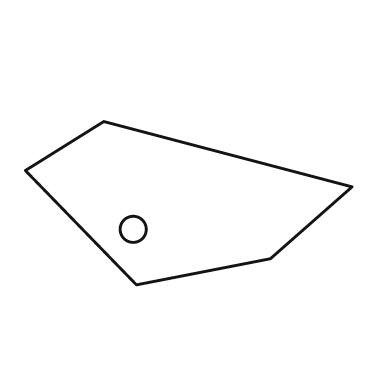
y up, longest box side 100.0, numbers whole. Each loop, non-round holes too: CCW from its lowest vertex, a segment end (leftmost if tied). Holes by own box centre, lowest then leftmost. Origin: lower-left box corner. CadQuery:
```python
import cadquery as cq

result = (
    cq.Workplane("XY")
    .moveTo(34.0, 0.0)
    .lineTo(75.0, 8.0)
    .lineTo(100.0, 30.0)
    .lineTo(24.0, 50.0)
    .lineTo(0.0, 35.0)
    .close()
    .moveTo(33.0, 17.0)
    .circle(4.0)
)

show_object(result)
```